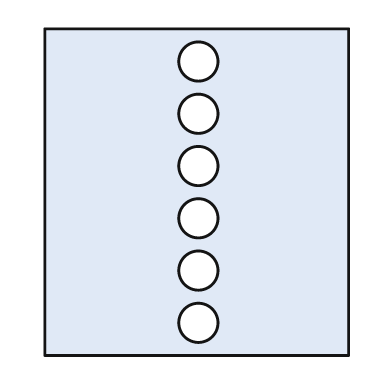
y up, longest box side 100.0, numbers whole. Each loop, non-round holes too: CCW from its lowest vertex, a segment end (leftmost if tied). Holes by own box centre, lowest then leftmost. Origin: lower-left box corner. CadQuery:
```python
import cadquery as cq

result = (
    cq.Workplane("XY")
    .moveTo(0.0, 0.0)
    .lineTo(93.0, 0.0)
    .lineTo(93.0, 100.0)
    .lineTo(0.0, 100.0)
    .close()
    .moveTo(47.0, 10.0)
    .circle(6.0)
    .moveTo(47.0, 26.0)
    .circle(6.0)
    .moveTo(47.0, 42.0)
    .circle(6.0)
    .moveTo(47.0, 58.0)
    .circle(6.0)
    .moveTo(47.0, 74.0)
    .circle(6.0)
    .moveTo(47.0, 90.0)
    .circle(6.0)
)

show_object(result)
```